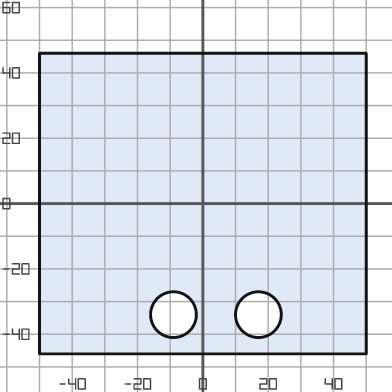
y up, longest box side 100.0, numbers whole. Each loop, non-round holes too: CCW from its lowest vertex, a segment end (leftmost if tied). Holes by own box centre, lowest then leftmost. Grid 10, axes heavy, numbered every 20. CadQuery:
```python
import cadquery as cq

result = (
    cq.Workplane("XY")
    .moveTo(-50.0, -46.0)
    .lineTo(50.0, -46.0)
    .lineTo(50.0, 46.0)
    .lineTo(-50.0, 46.0)
    .close()
    .moveTo(-9.0, -34.0)
    .circle(7.0)
    .moveTo(17.0, -34.0)
    .circle(7.0)
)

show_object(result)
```